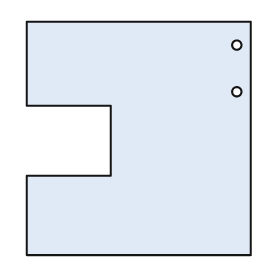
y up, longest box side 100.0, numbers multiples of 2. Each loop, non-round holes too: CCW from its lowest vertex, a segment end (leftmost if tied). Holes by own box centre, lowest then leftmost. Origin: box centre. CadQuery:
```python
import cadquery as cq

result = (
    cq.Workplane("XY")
    .moveTo(-48.0, -50.0)
    .lineTo(48.0, -50.0)
    .lineTo(48.0, 50.0)
    .lineTo(-48.0, 50.0)
    .lineTo(-48.0, 14.0)
    .lineTo(-12.0, 14.0)
    .lineTo(-12.0, -16.0)
    .lineTo(-48.0, -16.0)
    .close()
    .moveTo(42.0, 20.0)
    .circle(2.0)
    .moveTo(42.0, 40.0)
    .circle(2.0)
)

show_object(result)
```